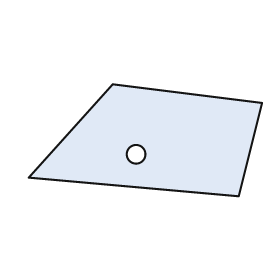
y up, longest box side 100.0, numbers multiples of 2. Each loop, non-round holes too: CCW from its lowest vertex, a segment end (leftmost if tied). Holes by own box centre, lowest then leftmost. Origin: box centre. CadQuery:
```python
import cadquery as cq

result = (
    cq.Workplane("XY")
    .moveTo(40.0, -24.0)
    .lineTo(50.0, 16.0)
    .lineTo(-14.0, 24.0)
    .lineTo(-50.0, -16.0)
    .close()
    .moveTo(-4.0, -6.0)
    .circle(4.0)
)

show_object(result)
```